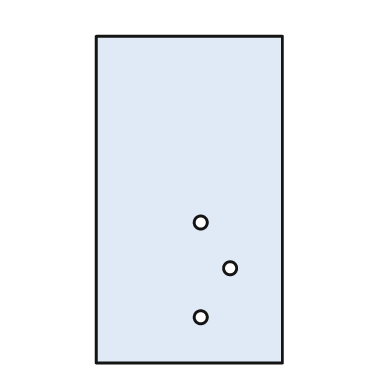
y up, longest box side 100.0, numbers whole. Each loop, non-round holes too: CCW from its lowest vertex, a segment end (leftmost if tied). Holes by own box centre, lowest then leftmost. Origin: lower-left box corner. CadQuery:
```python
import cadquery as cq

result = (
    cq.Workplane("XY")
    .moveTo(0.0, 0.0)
    .lineTo(57.0, 0.0)
    .lineTo(57.0, 100.0)
    .lineTo(0.0, 100.0)
    .close()
    .moveTo(32.0, 14.0)
    .circle(2.0)
    .moveTo(41.0, 29.0)
    .circle(2.0)
    .moveTo(32.0, 43.0)
    .circle(2.0)
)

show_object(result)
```